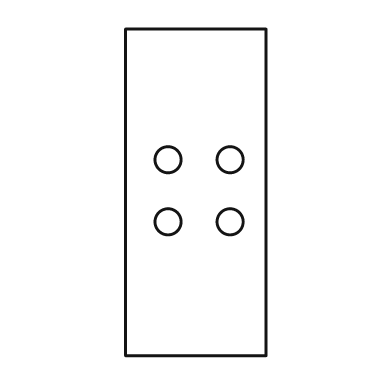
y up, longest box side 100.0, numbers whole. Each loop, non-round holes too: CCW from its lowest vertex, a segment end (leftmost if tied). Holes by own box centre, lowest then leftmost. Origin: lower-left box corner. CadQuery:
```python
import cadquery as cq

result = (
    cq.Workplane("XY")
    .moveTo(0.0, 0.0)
    .lineTo(43.0, 0.0)
    .lineTo(43.0, 100.0)
    .lineTo(0.0, 100.0)
    .close()
    .moveTo(13.0, 41.0)
    .circle(4.0)
    .moveTo(32.0, 41.0)
    .circle(4.0)
    .moveTo(13.0, 60.0)
    .circle(4.0)
    .moveTo(32.0, 60.0)
    .circle(4.0)
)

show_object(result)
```